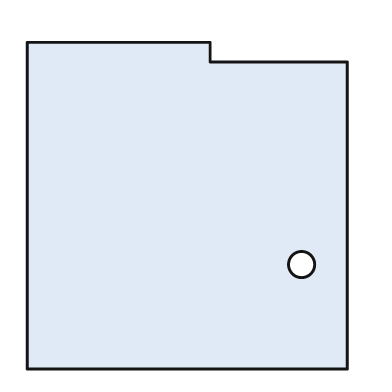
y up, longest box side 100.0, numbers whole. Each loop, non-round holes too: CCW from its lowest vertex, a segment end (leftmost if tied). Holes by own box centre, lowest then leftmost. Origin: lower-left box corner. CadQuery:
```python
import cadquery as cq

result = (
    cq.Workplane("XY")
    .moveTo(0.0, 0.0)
    .lineTo(98.0, 0.0)
    .lineTo(98.0, 94.0)
    .lineTo(56.0, 94.0)
    .lineTo(56.0, 100.0)
    .lineTo(0.0, 100.0)
    .close()
    .moveTo(84.0, 32.0)
    .circle(4.0)
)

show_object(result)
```